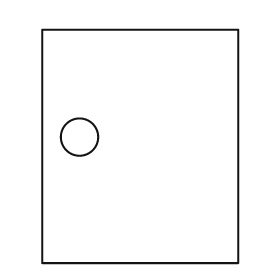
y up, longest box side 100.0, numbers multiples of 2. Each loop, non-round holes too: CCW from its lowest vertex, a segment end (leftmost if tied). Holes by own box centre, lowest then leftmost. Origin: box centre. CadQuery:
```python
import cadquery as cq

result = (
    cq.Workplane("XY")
    .moveTo(-42.0, -50.0)
    .lineTo(42.0, -50.0)
    .lineTo(42.0, 50.0)
    .lineTo(-42.0, 50.0)
    .close()
    .moveTo(-26.0, 4.0)
    .circle(8.0)
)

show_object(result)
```